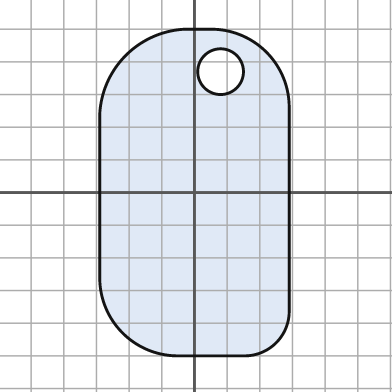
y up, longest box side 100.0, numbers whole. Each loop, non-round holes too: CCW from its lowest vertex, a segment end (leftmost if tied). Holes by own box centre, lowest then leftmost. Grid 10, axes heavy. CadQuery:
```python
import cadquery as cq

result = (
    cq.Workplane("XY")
    .moveTo(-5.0, -50.0)
    .lineTo(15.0, -50.0)
    .threePointArc((25.0, -46.0), (29.0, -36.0))
    .lineTo(29.0, 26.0)
    .threePointArc((22.0, 43.0), (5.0, 50.0))
    .lineTo(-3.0, 50.0)
    .threePointArc((-21.0, 42.0), (-29.0, 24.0))
    .lineTo(-29.0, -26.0)
    .threePointArc((-22.0, -43.0), (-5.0, -50.0))
    .close()
    .moveTo(8.0, 37.0)
    .circle(7.0)
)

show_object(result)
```